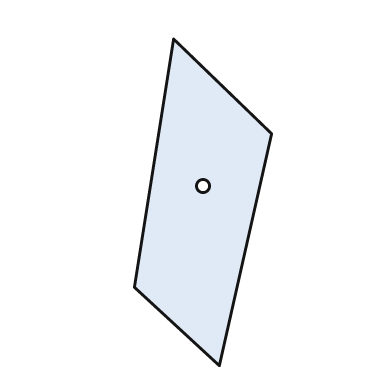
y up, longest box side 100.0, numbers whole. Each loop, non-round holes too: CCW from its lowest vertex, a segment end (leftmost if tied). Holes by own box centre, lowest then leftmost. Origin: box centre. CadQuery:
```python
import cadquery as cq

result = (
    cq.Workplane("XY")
    .moveTo(5.0, -50.0)
    .lineTo(21.0, 21.0)
    .lineTo(-9.0, 50.0)
    .lineTo(-21.0, -26.0)
    .close()
    .moveTo(0.0, 5.0)
    .circle(2.0)
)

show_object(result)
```